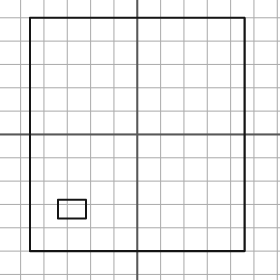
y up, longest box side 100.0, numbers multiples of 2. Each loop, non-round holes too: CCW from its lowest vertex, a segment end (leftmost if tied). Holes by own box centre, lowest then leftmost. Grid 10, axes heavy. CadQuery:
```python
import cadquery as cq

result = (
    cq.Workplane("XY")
    .moveTo(-46.0, -50.0)
    .lineTo(46.0, -50.0)
    .lineTo(46.0, 50.0)
    .lineTo(-46.0, 50.0)
    .close()
    .moveTo(-34.0, -36.0)
    .lineTo(-22.0, -36.0)
    .lineTo(-22.0, -28.0)
    .lineTo(-34.0, -28.0)
    .close()
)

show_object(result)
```